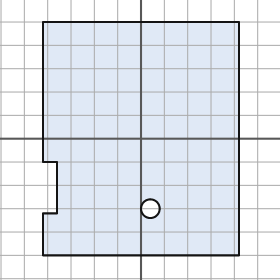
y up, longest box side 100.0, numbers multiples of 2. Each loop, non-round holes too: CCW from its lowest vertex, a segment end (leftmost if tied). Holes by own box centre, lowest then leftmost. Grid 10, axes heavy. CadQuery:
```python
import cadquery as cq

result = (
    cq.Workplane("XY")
    .moveTo(-42.0, -50.0)
    .lineTo(42.0, -50.0)
    .lineTo(42.0, 50.0)
    .lineTo(-42.0, 50.0)
    .lineTo(-42.0, -10.0)
    .lineTo(-36.0, -10.0)
    .lineTo(-36.0, -32.0)
    .lineTo(-42.0, -32.0)
    .close()
    .moveTo(4.0, -30.0)
    .circle(4.0)
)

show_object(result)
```